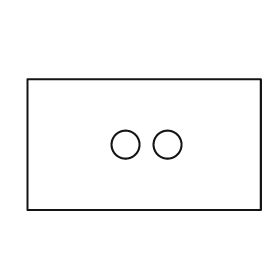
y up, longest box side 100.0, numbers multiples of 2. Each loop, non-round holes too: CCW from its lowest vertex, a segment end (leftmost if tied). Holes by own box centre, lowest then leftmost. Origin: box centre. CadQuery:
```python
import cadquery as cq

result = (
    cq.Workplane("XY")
    .moveTo(-50.0, -28.0)
    .lineTo(50.0, -28.0)
    .lineTo(50.0, 28.0)
    .lineTo(-50.0, 28.0)
    .close()
    .moveTo(-8.0, 0.0)
    .circle(6.0)
    .moveTo(10.0, 0.0)
    .circle(6.0)
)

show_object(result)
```